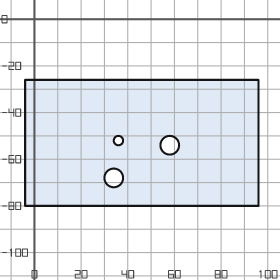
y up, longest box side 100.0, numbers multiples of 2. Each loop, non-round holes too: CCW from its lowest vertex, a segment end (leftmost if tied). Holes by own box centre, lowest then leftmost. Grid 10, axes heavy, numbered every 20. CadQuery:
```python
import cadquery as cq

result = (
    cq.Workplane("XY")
    .moveTo(-4.0, -80.0)
    .lineTo(96.0, -80.0)
    .lineTo(96.0, -26.0)
    .lineTo(-4.0, -26.0)
    .close()
    .moveTo(34.0, -68.0)
    .circle(4.0)
    .moveTo(58.0, -54.0)
    .circle(4.0)
    .moveTo(36.0, -52.0)
    .circle(2.0)
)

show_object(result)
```